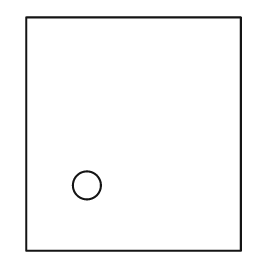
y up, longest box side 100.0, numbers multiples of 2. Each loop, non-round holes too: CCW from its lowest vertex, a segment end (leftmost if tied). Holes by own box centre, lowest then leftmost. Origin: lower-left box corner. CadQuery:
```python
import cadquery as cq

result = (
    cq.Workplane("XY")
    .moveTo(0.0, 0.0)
    .lineTo(92.0, 0.0)
    .lineTo(92.0, 100.0)
    .lineTo(0.0, 100.0)
    .close()
    .moveTo(26.0, 28.0)
    .circle(6.0)
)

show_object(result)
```